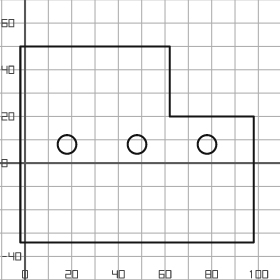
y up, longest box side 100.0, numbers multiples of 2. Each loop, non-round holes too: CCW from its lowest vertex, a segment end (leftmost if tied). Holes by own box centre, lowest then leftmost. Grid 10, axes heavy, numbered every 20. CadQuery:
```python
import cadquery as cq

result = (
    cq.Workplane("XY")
    .moveTo(-2.0, -34.0)
    .lineTo(98.0, -34.0)
    .lineTo(98.0, 20.0)
    .lineTo(62.0, 20.0)
    .lineTo(62.0, 50.0)
    .lineTo(-2.0, 50.0)
    .close()
    .moveTo(18.0, 8.0)
    .circle(4.0)
    .moveTo(48.0, 8.0)
    .circle(4.0)
    .moveTo(78.0, 8.0)
    .circle(4.0)
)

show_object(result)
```